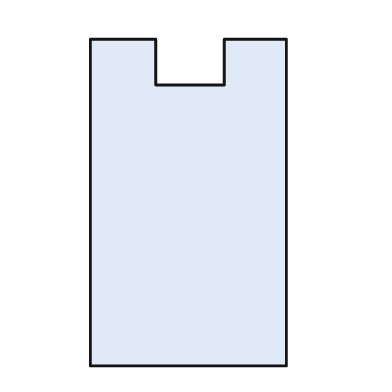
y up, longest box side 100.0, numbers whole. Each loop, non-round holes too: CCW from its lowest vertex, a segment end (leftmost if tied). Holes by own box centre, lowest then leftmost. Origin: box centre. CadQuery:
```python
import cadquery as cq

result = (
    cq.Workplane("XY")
    .moveTo(-30.0, -50.0)
    .lineTo(30.0, -50.0)
    .lineTo(30.0, 50.0)
    .lineTo(11.0, 50.0)
    .lineTo(11.0, 36.0)
    .lineTo(-10.0, 36.0)
    .lineTo(-10.0, 50.0)
    .lineTo(-30.0, 50.0)
    .close()
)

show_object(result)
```